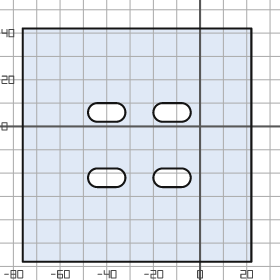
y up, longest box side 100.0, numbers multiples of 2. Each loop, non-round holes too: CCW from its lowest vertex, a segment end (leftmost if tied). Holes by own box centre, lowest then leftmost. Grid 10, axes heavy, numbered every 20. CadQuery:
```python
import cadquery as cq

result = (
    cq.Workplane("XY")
    .moveTo(-76.0, -58.0)
    .lineTo(22.0, -58.0)
    .lineTo(22.0, 42.0)
    .lineTo(-76.0, 42.0)
    .close()
    .moveTo(-44.0, -26.0)
    .lineTo(-36.0, -26.0)
    .threePointArc((-32.0, -22.0), (-36.0, -18.0))
    .lineTo(-44.0, -18.0)
    .threePointArc((-48.0, -22.0), (-44.0, -26.0))
    .close()
    .moveTo(-16.0, -26.0)
    .lineTo(-8.0, -26.0)
    .threePointArc((-4.0, -22.0), (-8.0, -18.0))
    .lineTo(-16.0, -18.0)
    .threePointArc((-20.0, -22.0), (-16.0, -26.0))
    .close()
    .moveTo(-44.0, 2.0)
    .lineTo(-36.0, 2.0)
    .threePointArc((-32.0, 6.0), (-36.0, 10.0))
    .lineTo(-44.0, 10.0)
    .threePointArc((-48.0, 6.0), (-44.0, 2.0))
    .close()
    .moveTo(-16.0, 2.0)
    .lineTo(-8.0, 2.0)
    .threePointArc((-4.0, 6.0), (-8.0, 10.0))
    .lineTo(-16.0, 10.0)
    .threePointArc((-20.0, 6.0), (-16.0, 2.0))
    .close()
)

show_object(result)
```